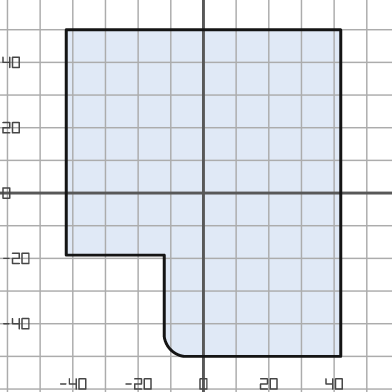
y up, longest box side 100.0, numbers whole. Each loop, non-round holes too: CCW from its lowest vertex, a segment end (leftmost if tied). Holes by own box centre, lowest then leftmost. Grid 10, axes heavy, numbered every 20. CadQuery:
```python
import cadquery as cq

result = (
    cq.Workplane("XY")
    .moveTo(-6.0, -50.0)
    .lineTo(42.0, -50.0)
    .lineTo(42.0, 50.0)
    .lineTo(-42.0, 50.0)
    .lineTo(-42.0, -19.0)
    .lineTo(-12.0, -19.0)
    .lineTo(-12.0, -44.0)
    .threePointArc((-10.0, -48.0), (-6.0, -50.0))
    .close()
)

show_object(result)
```